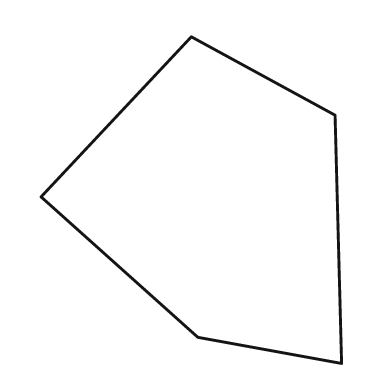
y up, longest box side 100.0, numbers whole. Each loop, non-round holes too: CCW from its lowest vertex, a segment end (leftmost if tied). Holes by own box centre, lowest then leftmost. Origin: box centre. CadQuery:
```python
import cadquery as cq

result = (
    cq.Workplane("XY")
    .moveTo(46.0, -50.0)
    .lineTo(44.0, 26.0)
    .lineTo(0.0, 50.0)
    .lineTo(-46.0, 1.0)
    .lineTo(2.0, -42.0)
    .close()
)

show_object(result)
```